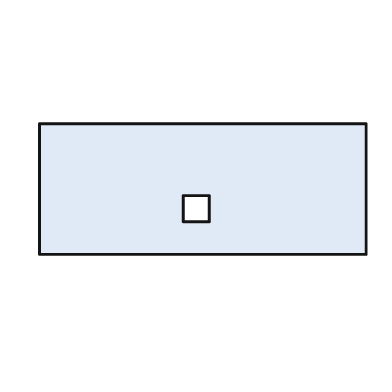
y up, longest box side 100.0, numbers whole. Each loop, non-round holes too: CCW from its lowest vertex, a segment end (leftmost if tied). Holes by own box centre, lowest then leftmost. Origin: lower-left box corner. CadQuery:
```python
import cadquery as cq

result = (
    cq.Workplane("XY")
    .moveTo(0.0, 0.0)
    .lineTo(100.0, 0.0)
    .lineTo(100.0, 40.0)
    .lineTo(0.0, 40.0)
    .close()
    .moveTo(44.0, 10.0)
    .lineTo(52.0, 10.0)
    .lineTo(52.0, 18.0)
    .lineTo(44.0, 18.0)
    .close()
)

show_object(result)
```